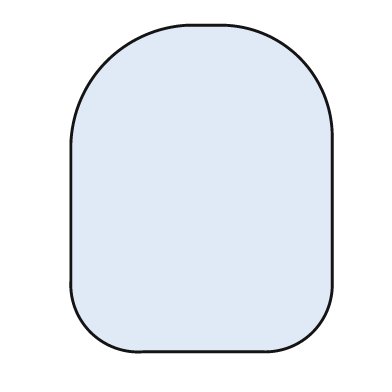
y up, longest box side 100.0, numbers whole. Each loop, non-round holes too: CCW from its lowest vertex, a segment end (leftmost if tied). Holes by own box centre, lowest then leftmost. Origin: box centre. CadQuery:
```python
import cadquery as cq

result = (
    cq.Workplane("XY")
    .moveTo(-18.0, -50.0)
    .lineTo(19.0, -50.0)
    .threePointArc((34.0, -44.0), (40.0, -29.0))
    .lineTo(40.0, 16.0)
    .threePointArc((30.0, 40.0), (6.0, 50.0))
    .lineTo(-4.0, 50.0)
    .threePointArc((-29.0, 39.0), (-40.0, 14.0))
    .lineTo(-40.0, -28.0)
    .threePointArc((-34.0, -44.0), (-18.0, -50.0))
    .close()
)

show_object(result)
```